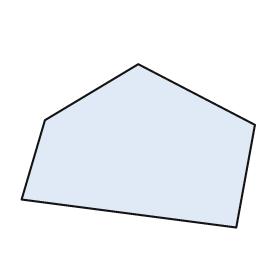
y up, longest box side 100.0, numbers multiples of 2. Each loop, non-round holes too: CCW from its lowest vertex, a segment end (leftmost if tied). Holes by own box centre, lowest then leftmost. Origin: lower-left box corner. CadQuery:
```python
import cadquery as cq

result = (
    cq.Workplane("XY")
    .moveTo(92.0, 0.0)
    .lineTo(100.0, 44.0)
    .lineTo(50.0, 70.0)
    .lineTo(10.0, 46.0)
    .lineTo(0.0, 12.0)
    .close()
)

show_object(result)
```